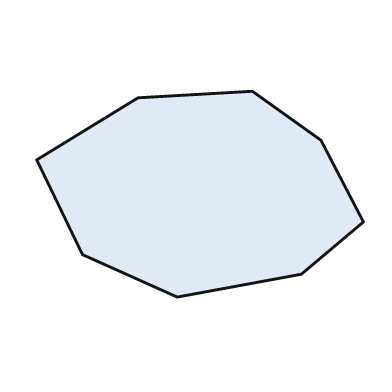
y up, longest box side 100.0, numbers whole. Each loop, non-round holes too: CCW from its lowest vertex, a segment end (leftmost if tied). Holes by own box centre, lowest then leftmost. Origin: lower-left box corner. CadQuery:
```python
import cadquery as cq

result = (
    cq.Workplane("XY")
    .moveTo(43.0, 0.0)
    .lineTo(81.0, 7.0)
    .lineTo(100.0, 23.0)
    .lineTo(87.0, 48.0)
    .lineTo(66.0, 63.0)
    .lineTo(31.0, 61.0)
    .lineTo(0.0, 42.0)
    .lineTo(14.0, 13.0)
    .close()
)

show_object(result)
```